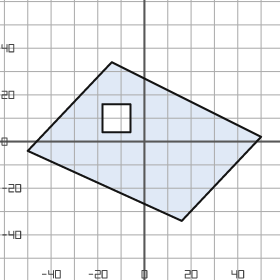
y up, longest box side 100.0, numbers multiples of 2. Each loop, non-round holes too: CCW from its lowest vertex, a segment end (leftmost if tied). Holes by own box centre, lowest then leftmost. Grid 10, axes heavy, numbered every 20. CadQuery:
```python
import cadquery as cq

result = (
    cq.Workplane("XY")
    .moveTo(16.0, -34.0)
    .lineTo(50.0, 2.0)
    .lineTo(-14.0, 34.0)
    .lineTo(-50.0, -4.0)
    .close()
    .moveTo(-18.0, 4.0)
    .lineTo(-6.0, 4.0)
    .lineTo(-6.0, 16.0)
    .lineTo(-18.0, 16.0)
    .close()
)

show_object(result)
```